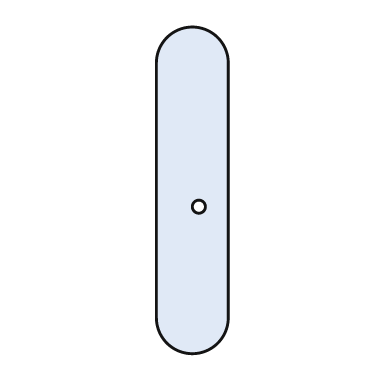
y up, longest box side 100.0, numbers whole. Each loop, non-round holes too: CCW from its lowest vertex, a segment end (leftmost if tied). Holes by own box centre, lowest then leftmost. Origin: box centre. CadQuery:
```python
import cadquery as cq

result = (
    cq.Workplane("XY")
    .moveTo(-11.0, -39.0)
    .threePointArc((0.0, -50.0), (11.0, -39.0))
    .lineTo(11.0, 39.0)
    .threePointArc((0.0, 50.0), (-11.0, 39.0))
    .close()
    .moveTo(2.0, -5.0)
    .circle(2.0)
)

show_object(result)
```